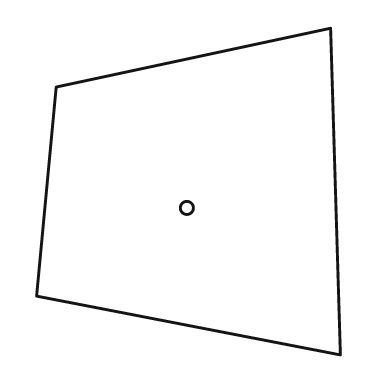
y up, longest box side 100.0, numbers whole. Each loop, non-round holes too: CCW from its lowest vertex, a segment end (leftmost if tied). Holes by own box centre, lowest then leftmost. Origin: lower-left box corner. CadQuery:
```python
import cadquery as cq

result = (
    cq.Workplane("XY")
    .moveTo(93.0, 0.0)
    .lineTo(90.0, 100.0)
    .lineTo(6.0, 82.0)
    .lineTo(0.0, 18.0)
    .close()
    .moveTo(46.0, 45.0)
    .circle(2.0)
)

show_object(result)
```